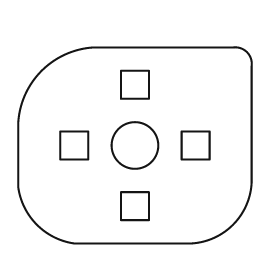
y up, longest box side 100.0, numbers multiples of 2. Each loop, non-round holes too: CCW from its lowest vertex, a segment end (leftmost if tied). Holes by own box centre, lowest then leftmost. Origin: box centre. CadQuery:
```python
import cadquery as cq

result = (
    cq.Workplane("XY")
    .moveTo(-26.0, -42.0)
    .lineTo(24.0, -42.0)
    .threePointArc((42.0, -34.0), (50.0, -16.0))
    .lineTo(50.0, 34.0)
    .threePointArc((48.0, 40.0), (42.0, 42.0))
    .lineTo(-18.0, 42.0)
    .threePointArc((-40.0, 32.0), (-50.0, 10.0))
    .lineTo(-50.0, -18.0)
    .threePointArc((-42.0, -34.0), (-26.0, -42.0))
    .close()
    .moveTo(-6.0, -32.0)
    .lineTo(6.0, -32.0)
    .lineTo(6.0, -20.0)
    .lineTo(-6.0, -20.0)
    .close()
    .moveTo(-32.0, -6.0)
    .lineTo(-20.0, -6.0)
    .lineTo(-20.0, 6.0)
    .lineTo(-32.0, 6.0)
    .close()
    .moveTo(0.0, 0.0)
    .circle(10.0)
    .moveTo(20.0, -6.0)
    .lineTo(32.0, -6.0)
    .lineTo(32.0, 6.0)
    .lineTo(20.0, 6.0)
    .close()
    .moveTo(-6.0, 20.0)
    .lineTo(6.0, 20.0)
    .lineTo(6.0, 32.0)
    .lineTo(-6.0, 32.0)
    .close()
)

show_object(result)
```